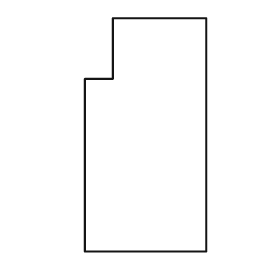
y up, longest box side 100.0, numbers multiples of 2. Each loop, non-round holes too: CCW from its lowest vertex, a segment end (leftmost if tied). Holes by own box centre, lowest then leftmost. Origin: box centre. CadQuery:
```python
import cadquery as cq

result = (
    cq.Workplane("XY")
    .moveTo(-26.0, -50.0)
    .lineTo(26.0, -50.0)
    .lineTo(26.0, 50.0)
    .lineTo(-14.0, 50.0)
    .lineTo(-14.0, 24.0)
    .lineTo(-26.0, 24.0)
    .close()
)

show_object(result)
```